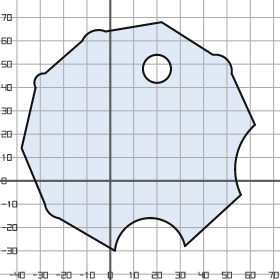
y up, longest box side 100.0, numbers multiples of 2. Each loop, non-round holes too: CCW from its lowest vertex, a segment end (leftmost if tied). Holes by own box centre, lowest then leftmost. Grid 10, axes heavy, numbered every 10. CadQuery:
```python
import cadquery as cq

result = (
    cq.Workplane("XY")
    .moveTo(2.0, -30.0)
    .threePointArc((16.0, -16.0), (32.0, -28.0))
    .lineTo(56.0, -6.0)
    .threePointArc((54.0, 10.0), (62.0, 24.0))
    .lineTo(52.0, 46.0)
    .threePointArc((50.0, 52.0), (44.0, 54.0))
    .lineTo(22.0, 68.0)
    .lineTo(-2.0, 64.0)
    .threePointArc((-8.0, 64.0), (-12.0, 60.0))
    .lineTo(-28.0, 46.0)
    .threePointArc((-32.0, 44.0), (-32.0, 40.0))
    .lineTo(-38.0, 14.0)
    .lineTo(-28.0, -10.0)
    .threePointArc((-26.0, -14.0), (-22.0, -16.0))
    .close()
    .moveTo(20.0, 48.0)
    .circle(6.0)
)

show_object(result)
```